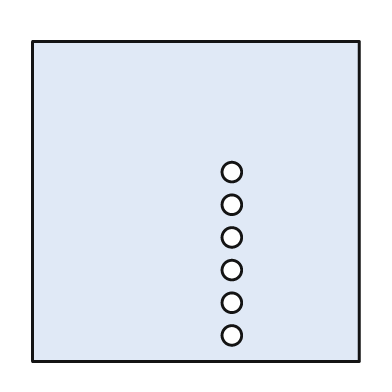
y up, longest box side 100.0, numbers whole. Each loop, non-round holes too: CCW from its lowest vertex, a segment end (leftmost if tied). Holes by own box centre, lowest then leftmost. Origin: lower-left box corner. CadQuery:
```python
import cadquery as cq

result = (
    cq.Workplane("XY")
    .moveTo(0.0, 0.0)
    .lineTo(100.0, 0.0)
    .lineTo(100.0, 98.0)
    .lineTo(0.0, 98.0)
    .close()
    .moveTo(61.0, 8.0)
    .circle(3.0)
    .moveTo(61.0, 18.0)
    .circle(3.0)
    .moveTo(61.0, 28.0)
    .circle(3.0)
    .moveTo(61.0, 38.0)
    .circle(3.0)
    .moveTo(61.0, 48.0)
    .circle(3.0)
    .moveTo(61.0, 58.0)
    .circle(3.0)
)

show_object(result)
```